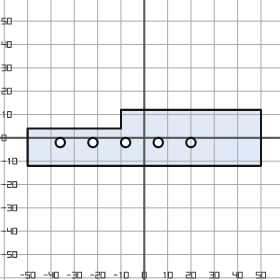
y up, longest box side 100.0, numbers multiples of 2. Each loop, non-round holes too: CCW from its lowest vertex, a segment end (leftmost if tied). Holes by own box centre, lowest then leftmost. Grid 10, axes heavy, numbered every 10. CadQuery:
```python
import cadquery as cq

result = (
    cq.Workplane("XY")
    .moveTo(-50.0, -12.0)
    .lineTo(50.0, -12.0)
    .lineTo(50.0, 12.0)
    .lineTo(-10.0, 12.0)
    .lineTo(-10.0, 4.0)
    .lineTo(-50.0, 4.0)
    .close()
    .moveTo(-36.0, -2.0)
    .circle(2.0)
    .moveTo(-22.0, -2.0)
    .circle(2.0)
    .moveTo(-8.0, -2.0)
    .circle(2.0)
    .moveTo(6.0, -2.0)
    .circle(2.0)
    .moveTo(20.0, -2.0)
    .circle(2.0)
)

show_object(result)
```